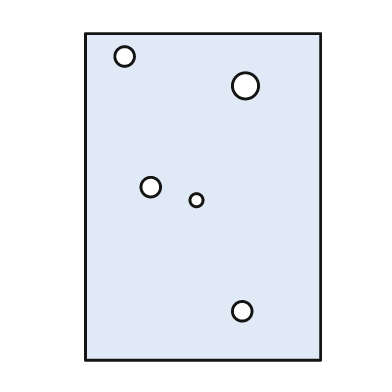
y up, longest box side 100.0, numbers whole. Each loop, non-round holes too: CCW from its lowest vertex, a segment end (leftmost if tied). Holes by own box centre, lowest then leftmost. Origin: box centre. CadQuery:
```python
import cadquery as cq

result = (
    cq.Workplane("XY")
    .moveTo(-36.0, -50.0)
    .lineTo(36.0, -50.0)
    .lineTo(36.0, 50.0)
    .lineTo(-36.0, 50.0)
    .close()
    .moveTo(12.0, -35.0)
    .circle(3.0)
    .moveTo(-2.0, -1.0)
    .circle(2.0)
    .moveTo(-16.0, 3.0)
    .circle(3.0)
    .moveTo(13.0, 34.0)
    .circle(4.0)
    .moveTo(-24.0, 43.0)
    .circle(3.0)
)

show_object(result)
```